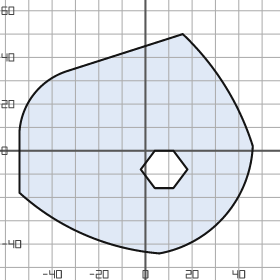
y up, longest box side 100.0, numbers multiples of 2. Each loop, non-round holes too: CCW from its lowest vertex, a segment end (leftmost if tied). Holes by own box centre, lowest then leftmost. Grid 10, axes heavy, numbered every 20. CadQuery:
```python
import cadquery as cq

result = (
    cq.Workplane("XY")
    .moveTo(6.0, -44.0)
    .threePointArc((34.0, -28.0), (46.0, 2.0))
    .threePointArc((34.0, 28.0), (16.0, 50.0))
    .lineTo(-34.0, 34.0)
    .threePointArc((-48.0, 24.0), (-54.0, 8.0))
    .lineTo(-54.0, -18.0)
    .threePointArc((-26.0, -36.0), (6.0, -44.0))
    .close()
    .moveTo(4.0, -16.0)
    .lineTo(12.0, -16.0)
    .lineTo(18.0, -8.0)
    .lineTo(12.0, 0.0)
    .lineTo(4.0, 0.0)
    .lineTo(-2.0, -8.0)
    .close()
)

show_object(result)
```